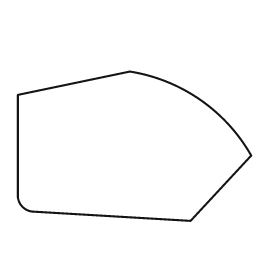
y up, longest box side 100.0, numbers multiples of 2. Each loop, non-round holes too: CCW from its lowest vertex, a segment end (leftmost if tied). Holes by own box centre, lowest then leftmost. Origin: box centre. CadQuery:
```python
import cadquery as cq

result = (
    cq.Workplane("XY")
    .moveTo(24.0, -32.0)
    .lineTo(50.0, -4.0)
    .threePointArc((28.0, 20.0), (-2.0, 32.0))
    .lineTo(-50.0, 22.0)
    .lineTo(-50.0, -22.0)
    .threePointArc((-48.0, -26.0), (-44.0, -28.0))
    .close()
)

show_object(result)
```